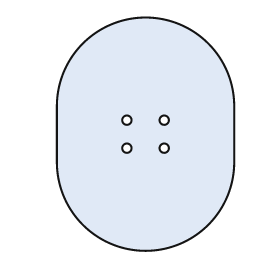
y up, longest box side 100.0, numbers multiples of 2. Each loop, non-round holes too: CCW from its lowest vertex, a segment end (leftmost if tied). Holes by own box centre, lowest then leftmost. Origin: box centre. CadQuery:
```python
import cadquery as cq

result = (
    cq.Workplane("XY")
    .moveTo(-38.0, -12.0)
    .threePointArc((0.0, -50.0), (38.0, -12.0))
    .lineTo(38.0, 12.0)
    .threePointArc((0.0, 50.0), (-38.0, 12.0))
    .close()
    .moveTo(-8.0, -6.0)
    .circle(2.0)
    .moveTo(8.0, -6.0)
    .circle(2.0)
    .moveTo(-8.0, 6.0)
    .circle(2.0)
    .moveTo(8.0, 6.0)
    .circle(2.0)
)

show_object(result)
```